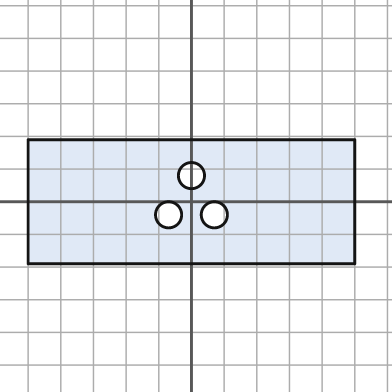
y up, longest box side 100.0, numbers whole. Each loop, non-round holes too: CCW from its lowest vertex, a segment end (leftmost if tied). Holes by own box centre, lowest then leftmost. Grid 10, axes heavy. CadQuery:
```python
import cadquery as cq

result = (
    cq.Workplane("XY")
    .moveTo(-50.0, -19.0)
    .lineTo(50.0, -19.0)
    .lineTo(50.0, 19.0)
    .lineTo(-50.0, 19.0)
    .close()
    .moveTo(-7.0, -4.0)
    .circle(4.0)
    .moveTo(7.0, -4.0)
    .circle(4.0)
    .moveTo(0.0, 8.0)
    .circle(4.0)
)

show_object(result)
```